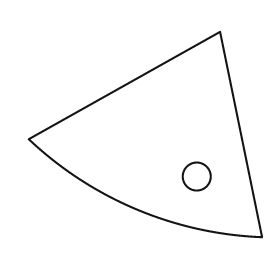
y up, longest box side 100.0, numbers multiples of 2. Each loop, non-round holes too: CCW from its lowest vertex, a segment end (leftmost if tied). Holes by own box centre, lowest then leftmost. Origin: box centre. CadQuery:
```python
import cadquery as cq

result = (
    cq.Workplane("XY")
    .moveTo(50.0, -44.0)
    .lineTo(32.0, 44.0)
    .lineTo(-50.0, -2.0)
    .threePointArc((-4.0, -32.0), (50.0, -44.0))
    .close()
    .moveTo(22.0, -18.0)
    .circle(6.0)
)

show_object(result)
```